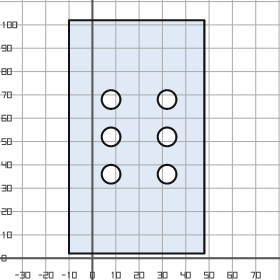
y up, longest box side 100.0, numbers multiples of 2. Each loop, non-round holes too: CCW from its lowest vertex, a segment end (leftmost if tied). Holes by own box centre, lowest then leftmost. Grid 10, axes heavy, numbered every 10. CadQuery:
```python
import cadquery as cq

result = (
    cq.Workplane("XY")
    .moveTo(-10.0, 2.0)
    .lineTo(48.0, 2.0)
    .lineTo(48.0, 102.0)
    .lineTo(-10.0, 102.0)
    .close()
    .moveTo(8.0, 36.0)
    .circle(4.0)
    .moveTo(32.0, 36.0)
    .circle(4.0)
    .moveTo(8.0, 52.0)
    .circle(4.0)
    .moveTo(32.0, 52.0)
    .circle(4.0)
    .moveTo(8.0, 68.0)
    .circle(4.0)
    .moveTo(32.0, 68.0)
    .circle(4.0)
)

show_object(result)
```